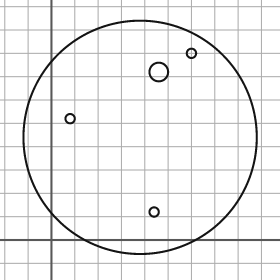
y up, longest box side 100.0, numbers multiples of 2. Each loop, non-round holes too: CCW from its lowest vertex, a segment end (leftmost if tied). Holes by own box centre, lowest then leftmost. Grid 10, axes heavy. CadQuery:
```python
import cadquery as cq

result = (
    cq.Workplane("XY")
    .moveTo(38.0, 44.0)
    .circle(50.0)
    .moveTo(44.0, 12.0)
    .circle(2.0)
    .moveTo(8.0, 52.0)
    .circle(2.0)
    .moveTo(46.0, 72.0)
    .circle(4.0)
    .moveTo(60.0, 80.0)
    .circle(2.0)
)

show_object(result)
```